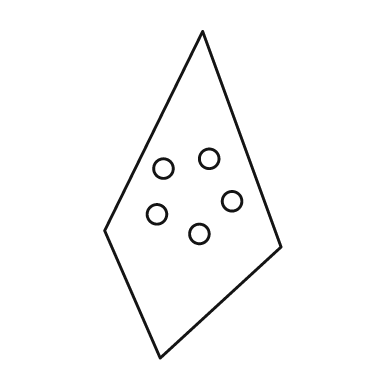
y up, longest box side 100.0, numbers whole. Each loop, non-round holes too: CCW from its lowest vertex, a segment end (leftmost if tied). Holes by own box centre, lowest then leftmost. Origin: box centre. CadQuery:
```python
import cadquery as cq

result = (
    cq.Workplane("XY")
    .moveTo(-10.0, -50.0)
    .lineTo(27.0, -16.0)
    .lineTo(3.0, 50.0)
    .lineTo(-27.0, -11.0)
    .close()
    .moveTo(2.0, -12.0)
    .circle(3.0)
    .moveTo(-11.0, -6.0)
    .circle(3.0)
    .moveTo(12.0, -2.0)
    .circle(3.0)
    .moveTo(-9.0, 8.0)
    .circle(3.0)
    .moveTo(5.0, 11.0)
    .circle(3.0)
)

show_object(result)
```